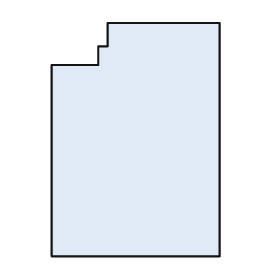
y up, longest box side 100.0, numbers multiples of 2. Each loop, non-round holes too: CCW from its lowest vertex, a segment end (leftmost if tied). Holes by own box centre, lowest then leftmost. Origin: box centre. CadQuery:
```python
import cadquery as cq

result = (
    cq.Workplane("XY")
    .moveTo(-36.0, -50.0)
    .lineTo(36.0, -50.0)
    .lineTo(36.0, 50.0)
    .lineTo(-12.0, 50.0)
    .lineTo(-12.0, 40.0)
    .lineTo(-16.0, 40.0)
    .lineTo(-16.0, 32.0)
    .lineTo(-36.0, 32.0)
    .close()
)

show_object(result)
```